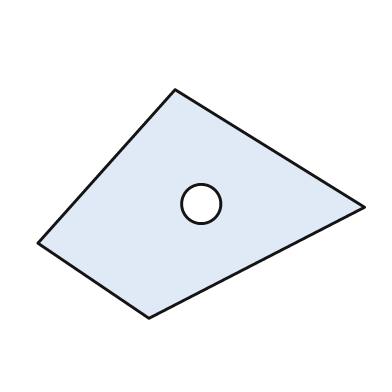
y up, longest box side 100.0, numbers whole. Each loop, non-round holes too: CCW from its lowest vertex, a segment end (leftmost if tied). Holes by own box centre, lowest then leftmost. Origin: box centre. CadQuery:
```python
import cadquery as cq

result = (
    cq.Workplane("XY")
    .moveTo(-16.0, -35.0)
    .lineTo(50.0, -1.0)
    .lineTo(-8.0, 35.0)
    .lineTo(-50.0, -12.0)
    .close()
    .moveTo(0.0, 0.0)
    .circle(6.0)
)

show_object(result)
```